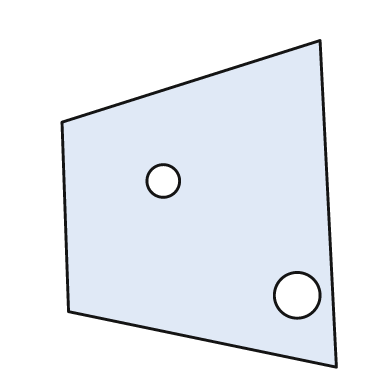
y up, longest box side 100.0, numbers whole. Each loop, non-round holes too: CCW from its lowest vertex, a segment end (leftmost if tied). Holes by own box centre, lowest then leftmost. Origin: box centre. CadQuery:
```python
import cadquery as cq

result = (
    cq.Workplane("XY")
    .moveTo(42.0, -50.0)
    .lineTo(37.0, 50.0)
    .lineTo(-42.0, 25.0)
    .lineTo(-40.0, -33.0)
    .close()
    .moveTo(30.0, -28.0)
    .circle(7.0)
    .moveTo(-11.0, 7.0)
    .circle(5.0)
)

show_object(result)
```